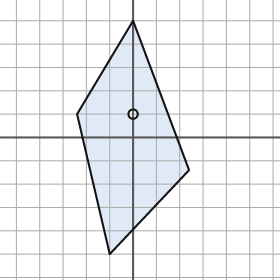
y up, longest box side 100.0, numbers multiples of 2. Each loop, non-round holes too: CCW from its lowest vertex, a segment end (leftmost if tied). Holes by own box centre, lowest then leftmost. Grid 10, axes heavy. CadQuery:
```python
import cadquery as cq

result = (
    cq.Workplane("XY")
    .moveTo(-10.0, -50.0)
    .lineTo(24.0, -14.0)
    .lineTo(0.0, 50.0)
    .lineTo(-24.0, 10.0)
    .close()
    .moveTo(0.0, 10.0)
    .circle(2.0)
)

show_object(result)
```